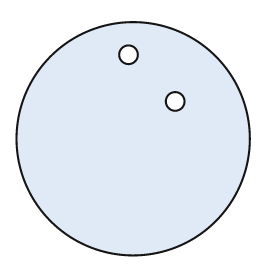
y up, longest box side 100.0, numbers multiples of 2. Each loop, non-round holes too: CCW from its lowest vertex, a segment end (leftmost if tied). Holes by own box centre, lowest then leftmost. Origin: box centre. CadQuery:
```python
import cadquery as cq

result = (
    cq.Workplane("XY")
    .moveTo(0.0, 0.0)
    .circle(50.0)
    .moveTo(18.0, 16.0)
    .circle(4.0)
    .moveTo(-2.0, 36.0)
    .circle(4.0)
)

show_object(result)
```